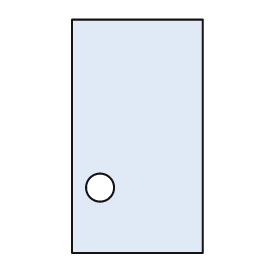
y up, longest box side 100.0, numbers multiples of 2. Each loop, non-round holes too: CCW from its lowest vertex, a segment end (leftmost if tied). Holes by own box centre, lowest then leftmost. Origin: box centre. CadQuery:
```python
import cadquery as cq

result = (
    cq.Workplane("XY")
    .moveTo(-28.0, -50.0)
    .lineTo(28.0, -50.0)
    .lineTo(28.0, 50.0)
    .lineTo(-28.0, 50.0)
    .close()
    .moveTo(-16.0, -22.0)
    .circle(6.0)
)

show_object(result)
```